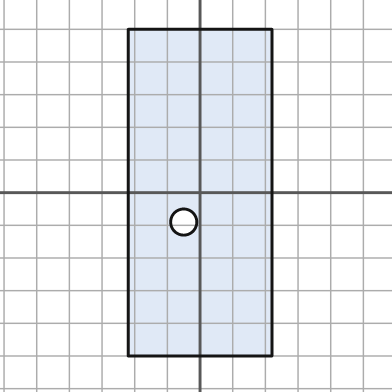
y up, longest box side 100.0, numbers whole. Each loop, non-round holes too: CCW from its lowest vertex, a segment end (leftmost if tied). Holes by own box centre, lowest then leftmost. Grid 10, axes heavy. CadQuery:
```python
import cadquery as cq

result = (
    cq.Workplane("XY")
    .moveTo(-22.0, -50.0)
    .lineTo(22.0, -50.0)
    .lineTo(22.0, 50.0)
    .lineTo(-22.0, 50.0)
    .close()
    .moveTo(-5.0, -9.0)
    .circle(4.0)
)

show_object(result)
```